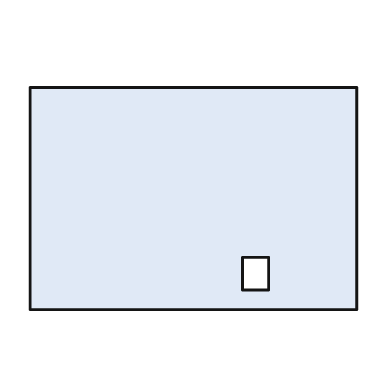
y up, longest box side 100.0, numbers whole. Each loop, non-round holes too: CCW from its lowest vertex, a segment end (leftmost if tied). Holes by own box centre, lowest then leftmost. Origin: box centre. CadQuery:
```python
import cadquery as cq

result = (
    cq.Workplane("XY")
    .moveTo(-50.0, -34.0)
    .lineTo(50.0, -34.0)
    .lineTo(50.0, 34.0)
    .lineTo(-50.0, 34.0)
    .close()
    .moveTo(15.0, -28.0)
    .lineTo(23.0, -28.0)
    .lineTo(23.0, -18.0)
    .lineTo(15.0, -18.0)
    .close()
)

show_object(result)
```